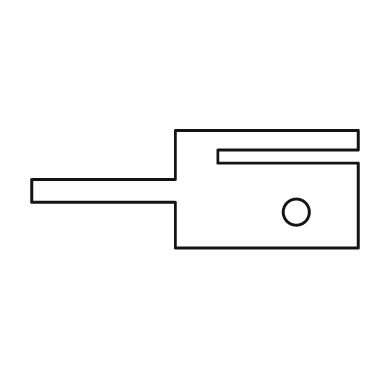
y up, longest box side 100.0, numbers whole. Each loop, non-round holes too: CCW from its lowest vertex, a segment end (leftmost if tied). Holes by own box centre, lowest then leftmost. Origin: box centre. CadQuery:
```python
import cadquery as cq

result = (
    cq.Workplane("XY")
    .moveTo(-6.0, -18.0)
    .lineTo(50.0, -18.0)
    .lineTo(50.0, 8.0)
    .lineTo(7.0, 8.0)
    .lineTo(7.0, 12.0)
    .lineTo(50.0, 12.0)
    .lineTo(50.0, 18.0)
    .lineTo(-6.0, 18.0)
    .lineTo(-6.0, 3.0)
    .lineTo(-50.0, 3.0)
    .lineTo(-50.0, -4.0)
    .lineTo(-6.0, -4.0)
    .close()
    .moveTo(31.0, -7.0)
    .circle(4.0)
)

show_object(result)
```